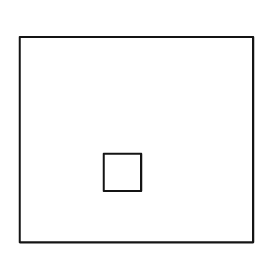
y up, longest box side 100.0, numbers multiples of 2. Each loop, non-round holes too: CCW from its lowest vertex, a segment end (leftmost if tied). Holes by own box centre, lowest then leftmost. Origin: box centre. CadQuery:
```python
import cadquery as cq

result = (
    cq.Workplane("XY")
    .moveTo(-50.0, -44.0)
    .lineTo(50.0, -44.0)
    .lineTo(50.0, 44.0)
    .lineTo(-50.0, 44.0)
    .close()
    .moveTo(-14.0, -22.0)
    .lineTo(2.0, -22.0)
    .lineTo(2.0, -6.0)
    .lineTo(-14.0, -6.0)
    .close()
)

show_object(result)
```